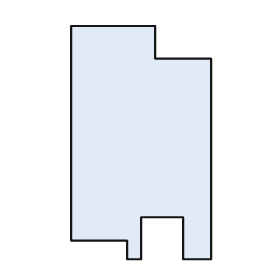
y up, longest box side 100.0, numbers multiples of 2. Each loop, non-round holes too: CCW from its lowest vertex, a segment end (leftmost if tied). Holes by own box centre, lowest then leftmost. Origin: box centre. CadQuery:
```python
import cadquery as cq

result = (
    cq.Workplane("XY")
    .moveTo(-6.0, -50.0)
    .lineTo(0.0, -50.0)
    .lineTo(0.0, -32.0)
    .lineTo(18.0, -32.0)
    .lineTo(18.0, -50.0)
    .lineTo(30.0, -50.0)
    .lineTo(30.0, 36.0)
    .lineTo(6.0, 36.0)
    .lineTo(6.0, 50.0)
    .lineTo(-30.0, 50.0)
    .lineTo(-30.0, -42.0)
    .lineTo(-6.0, -42.0)
    .close()
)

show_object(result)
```